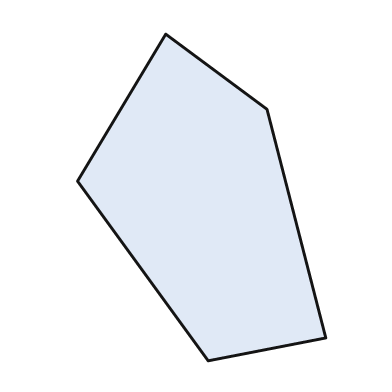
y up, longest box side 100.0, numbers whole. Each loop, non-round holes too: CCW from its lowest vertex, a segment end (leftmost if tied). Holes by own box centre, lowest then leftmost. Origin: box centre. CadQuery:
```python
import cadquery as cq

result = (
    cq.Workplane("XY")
    .moveTo(2.0, -50.0)
    .lineTo(38.0, -43.0)
    .lineTo(20.0, 27.0)
    .lineTo(-11.0, 50.0)
    .lineTo(-38.0, 5.0)
    .close()
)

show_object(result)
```